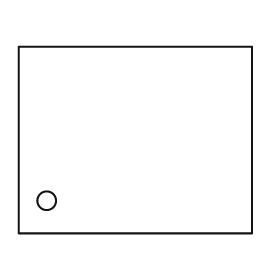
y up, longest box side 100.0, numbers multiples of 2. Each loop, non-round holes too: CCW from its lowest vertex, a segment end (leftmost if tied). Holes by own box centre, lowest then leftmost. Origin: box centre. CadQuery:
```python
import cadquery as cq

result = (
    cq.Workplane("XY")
    .moveTo(-50.0, -40.0)
    .lineTo(50.0, -40.0)
    .lineTo(50.0, 40.0)
    .lineTo(-50.0, 40.0)
    .close()
    .moveTo(-38.0, -26.0)
    .circle(4.0)
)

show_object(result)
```